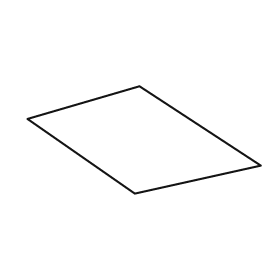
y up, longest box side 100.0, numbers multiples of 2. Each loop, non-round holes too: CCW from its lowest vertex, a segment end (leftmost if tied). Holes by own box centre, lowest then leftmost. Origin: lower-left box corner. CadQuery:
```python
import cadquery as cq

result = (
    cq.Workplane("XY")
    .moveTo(46.0, 0.0)
    .lineTo(100.0, 12.0)
    .lineTo(48.0, 46.0)
    .lineTo(0.0, 32.0)
    .close()
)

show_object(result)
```